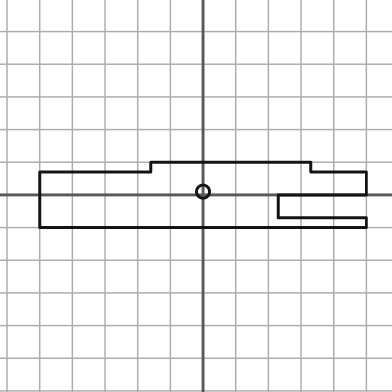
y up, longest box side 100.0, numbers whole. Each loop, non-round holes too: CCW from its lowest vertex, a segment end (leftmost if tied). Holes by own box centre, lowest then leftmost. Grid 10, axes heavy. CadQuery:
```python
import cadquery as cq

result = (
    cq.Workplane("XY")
    .moveTo(-50.0, -10.0)
    .lineTo(50.0, -10.0)
    .lineTo(50.0, -7.0)
    .lineTo(23.0, -7.0)
    .lineTo(23.0, 0.0)
    .lineTo(50.0, 0.0)
    .lineTo(50.0, 7.0)
    .lineTo(33.0, 7.0)
    .lineTo(33.0, 10.0)
    .lineTo(-16.0, 10.0)
    .lineTo(-16.0, 7.0)
    .lineTo(-50.0, 7.0)
    .close()
    .moveTo(0.0, 1.0)
    .circle(2.0)
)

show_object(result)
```